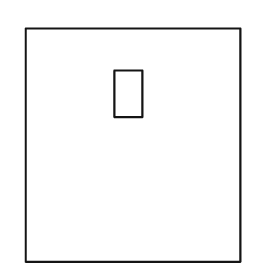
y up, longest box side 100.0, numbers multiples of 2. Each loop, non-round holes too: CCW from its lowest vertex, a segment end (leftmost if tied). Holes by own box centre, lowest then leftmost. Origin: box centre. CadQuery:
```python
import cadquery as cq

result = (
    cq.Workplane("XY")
    .moveTo(-46.0, -50.0)
    .lineTo(46.0, -50.0)
    .lineTo(46.0, 50.0)
    .lineTo(-46.0, 50.0)
    .close()
    .moveTo(-8.0, 12.0)
    .lineTo(4.0, 12.0)
    .lineTo(4.0, 32.0)
    .lineTo(-8.0, 32.0)
    .close()
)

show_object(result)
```